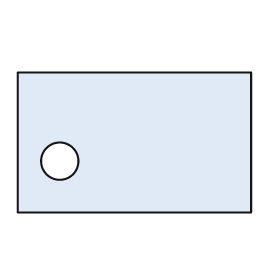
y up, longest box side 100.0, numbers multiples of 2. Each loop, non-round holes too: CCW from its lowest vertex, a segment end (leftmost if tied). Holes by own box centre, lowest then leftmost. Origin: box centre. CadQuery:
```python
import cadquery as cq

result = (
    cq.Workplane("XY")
    .moveTo(-50.0, -30.0)
    .lineTo(50.0, -30.0)
    .lineTo(50.0, 30.0)
    .lineTo(-50.0, 30.0)
    .close()
    .moveTo(-32.0, -8.0)
    .circle(8.0)
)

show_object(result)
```